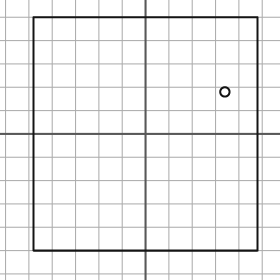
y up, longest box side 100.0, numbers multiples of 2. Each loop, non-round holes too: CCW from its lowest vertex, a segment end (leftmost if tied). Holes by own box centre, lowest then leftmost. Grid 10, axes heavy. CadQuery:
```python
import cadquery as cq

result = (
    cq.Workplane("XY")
    .moveTo(-48.0, -50.0)
    .lineTo(48.0, -50.0)
    .lineTo(48.0, 50.0)
    .lineTo(-48.0, 50.0)
    .close()
    .moveTo(34.0, 18.0)
    .circle(2.0)
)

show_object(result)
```